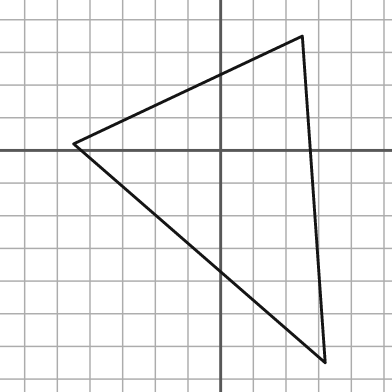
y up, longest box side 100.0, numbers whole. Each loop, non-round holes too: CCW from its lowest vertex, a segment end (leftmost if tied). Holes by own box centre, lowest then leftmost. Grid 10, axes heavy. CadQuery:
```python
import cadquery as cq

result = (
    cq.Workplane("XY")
    .moveTo(32.0, -65.0)
    .lineTo(25.0, 35.0)
    .lineTo(-45.0, 2.0)
    .close()
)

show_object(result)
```